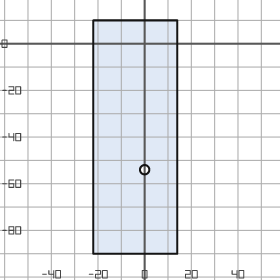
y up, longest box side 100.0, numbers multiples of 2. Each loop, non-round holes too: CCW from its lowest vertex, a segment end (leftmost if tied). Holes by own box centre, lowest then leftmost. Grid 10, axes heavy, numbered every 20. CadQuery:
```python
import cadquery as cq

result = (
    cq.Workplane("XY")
    .moveTo(-22.0, -90.0)
    .lineTo(14.0, -90.0)
    .lineTo(14.0, 10.0)
    .lineTo(-22.0, 10.0)
    .close()
    .moveTo(0.0, -54.0)
    .circle(2.0)
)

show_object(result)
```